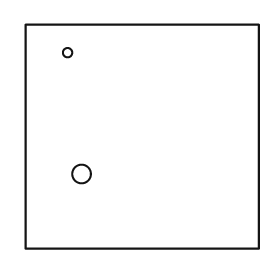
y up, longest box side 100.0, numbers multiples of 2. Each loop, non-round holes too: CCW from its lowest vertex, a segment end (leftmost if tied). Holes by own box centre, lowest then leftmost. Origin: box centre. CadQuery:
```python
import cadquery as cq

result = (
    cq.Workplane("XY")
    .moveTo(-50.0, -48.0)
    .lineTo(50.0, -48.0)
    .lineTo(50.0, 48.0)
    .lineTo(-50.0, 48.0)
    .close()
    .moveTo(-26.0, -16.0)
    .circle(4.0)
    .moveTo(-32.0, 36.0)
    .circle(2.0)
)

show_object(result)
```